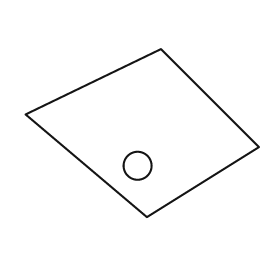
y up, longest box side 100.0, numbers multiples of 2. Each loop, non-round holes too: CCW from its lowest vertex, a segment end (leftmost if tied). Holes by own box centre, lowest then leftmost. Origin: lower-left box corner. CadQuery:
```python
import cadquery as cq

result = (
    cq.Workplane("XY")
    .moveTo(52.0, 0.0)
    .lineTo(100.0, 30.0)
    .lineTo(58.0, 72.0)
    .lineTo(0.0, 44.0)
    .close()
    .moveTo(48.0, 22.0)
    .circle(6.0)
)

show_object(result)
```